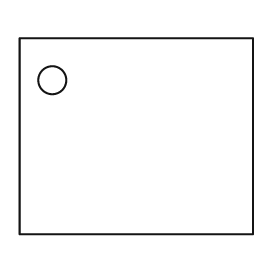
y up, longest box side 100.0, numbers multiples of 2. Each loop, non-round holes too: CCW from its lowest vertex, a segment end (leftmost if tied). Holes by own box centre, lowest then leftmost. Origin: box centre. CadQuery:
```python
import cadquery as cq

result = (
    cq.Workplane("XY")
    .moveTo(-50.0, -42.0)
    .lineTo(50.0, -42.0)
    .lineTo(50.0, 42.0)
    .lineTo(-50.0, 42.0)
    .close()
    .moveTo(-36.0, 24.0)
    .circle(6.0)
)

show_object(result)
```